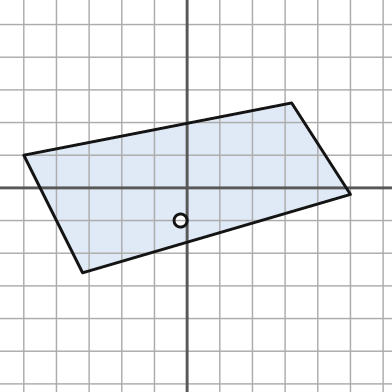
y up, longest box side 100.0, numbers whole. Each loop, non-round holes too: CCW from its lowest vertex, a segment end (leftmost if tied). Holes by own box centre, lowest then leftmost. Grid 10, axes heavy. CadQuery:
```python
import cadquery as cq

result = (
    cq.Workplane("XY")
    .moveTo(-32.0, -26.0)
    .lineTo(50.0, -2.0)
    .lineTo(32.0, 26.0)
    .lineTo(-50.0, 10.0)
    .close()
    .moveTo(-2.0, -10.0)
    .circle(2.0)
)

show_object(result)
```